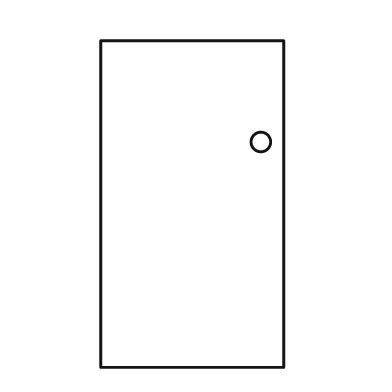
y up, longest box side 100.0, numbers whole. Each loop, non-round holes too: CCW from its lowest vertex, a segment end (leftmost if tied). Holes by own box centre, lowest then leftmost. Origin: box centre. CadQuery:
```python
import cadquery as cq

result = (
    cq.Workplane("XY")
    .moveTo(-28.0, -50.0)
    .lineTo(28.0, -50.0)
    .lineTo(28.0, 50.0)
    .lineTo(-28.0, 50.0)
    .close()
    .moveTo(21.0, 19.0)
    .circle(3.0)
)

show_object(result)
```